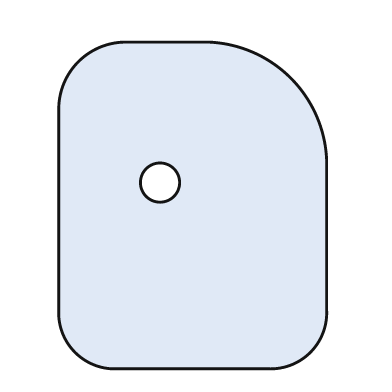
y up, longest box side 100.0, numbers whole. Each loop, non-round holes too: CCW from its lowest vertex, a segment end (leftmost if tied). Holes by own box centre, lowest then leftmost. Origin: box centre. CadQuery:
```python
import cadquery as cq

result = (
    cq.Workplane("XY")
    .moveTo(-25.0, -50.0)
    .lineTo(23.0, -50.0)
    .threePointArc((36.0, -45.0), (41.0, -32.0))
    .lineTo(41.0, 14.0)
    .threePointArc((30.0, 39.0), (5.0, 50.0))
    .lineTo(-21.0, 50.0)
    .threePointArc((-35.0, 44.0), (-41.0, 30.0))
    .lineTo(-41.0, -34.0)
    .threePointArc((-36.0, -45.0), (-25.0, -50.0))
    .close()
    .moveTo(-10.0, 7.0)
    .circle(6.0)
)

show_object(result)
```